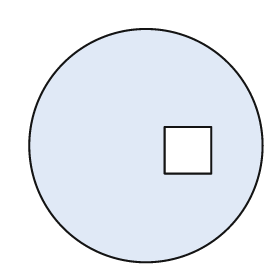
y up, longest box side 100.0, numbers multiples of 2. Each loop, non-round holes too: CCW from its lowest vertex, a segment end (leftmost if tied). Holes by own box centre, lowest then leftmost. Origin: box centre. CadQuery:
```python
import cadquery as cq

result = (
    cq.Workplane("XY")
    .moveTo(0.0, 0.0)
    .circle(50.0)
    .moveTo(8.0, -12.0)
    .lineTo(28.0, -12.0)
    .lineTo(28.0, 8.0)
    .lineTo(8.0, 8.0)
    .close()
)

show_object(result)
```